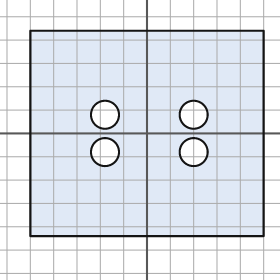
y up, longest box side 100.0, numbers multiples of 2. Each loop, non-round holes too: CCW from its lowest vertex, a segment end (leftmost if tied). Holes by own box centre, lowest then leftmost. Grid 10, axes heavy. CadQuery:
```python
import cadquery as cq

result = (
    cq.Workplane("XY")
    .moveTo(-50.0, -44.0)
    .lineTo(50.0, -44.0)
    .lineTo(50.0, 44.0)
    .lineTo(-50.0, 44.0)
    .close()
    .moveTo(-18.0, -8.0)
    .circle(6.0)
    .moveTo(20.0, -8.0)
    .circle(6.0)
    .moveTo(-18.0, 8.0)
    .circle(6.0)
    .moveTo(20.0, 8.0)
    .circle(6.0)
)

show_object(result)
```